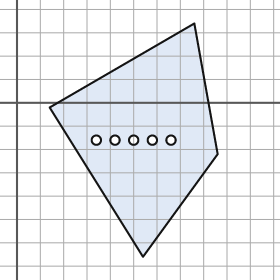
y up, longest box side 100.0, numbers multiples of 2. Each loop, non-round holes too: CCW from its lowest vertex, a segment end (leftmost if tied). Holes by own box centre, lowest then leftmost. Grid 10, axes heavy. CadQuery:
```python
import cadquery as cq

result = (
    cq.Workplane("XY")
    .moveTo(54.0, -66.0)
    .lineTo(86.0, -22.0)
    .lineTo(76.0, 34.0)
    .lineTo(14.0, -2.0)
    .close()
    .moveTo(34.0, -16.0)
    .circle(2.0)
    .moveTo(42.0, -16.0)
    .circle(2.0)
    .moveTo(50.0, -16.0)
    .circle(2.0)
    .moveTo(58.0, -16.0)
    .circle(2.0)
    .moveTo(66.0, -16.0)
    .circle(2.0)
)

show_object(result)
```